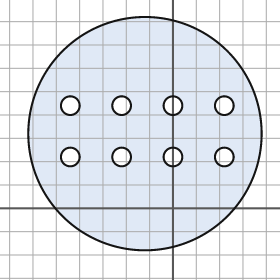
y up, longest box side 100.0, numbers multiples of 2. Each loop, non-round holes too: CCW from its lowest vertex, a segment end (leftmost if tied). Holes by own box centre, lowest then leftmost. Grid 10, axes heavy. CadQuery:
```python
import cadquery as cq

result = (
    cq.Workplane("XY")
    .moveTo(-12.0, 32.0)
    .circle(50.0)
    .moveTo(-44.0, 22.0)
    .circle(4.0)
    .moveTo(-22.0, 22.0)
    .circle(4.0)
    .moveTo(0.0, 22.0)
    .circle(4.0)
    .moveTo(22.0, 22.0)
    .circle(4.0)
    .moveTo(-44.0, 44.0)
    .circle(4.0)
    .moveTo(-22.0, 44.0)
    .circle(4.0)
    .moveTo(0.0, 44.0)
    .circle(4.0)
    .moveTo(22.0, 44.0)
    .circle(4.0)
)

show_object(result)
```